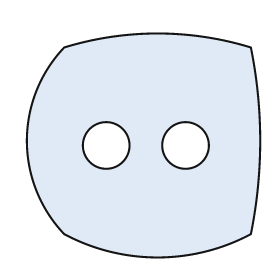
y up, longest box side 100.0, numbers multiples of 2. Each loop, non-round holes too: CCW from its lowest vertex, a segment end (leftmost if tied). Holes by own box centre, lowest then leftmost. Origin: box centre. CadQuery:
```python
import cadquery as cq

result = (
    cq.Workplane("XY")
    .moveTo(-34.0, -38.0)
    .threePointArc((6.0, -48.0), (46.0, -38.0))
    .threePointArc((50.0, 2.0), (46.0, 42.0))
    .threePointArc((6.0, 48.0), (-34.0, 42.0))
    .threePointArc((-50.0, 2.0), (-34.0, -38.0))
    .close()
    .moveTo(-16.0, 0.0)
    .circle(10.0)
    .moveTo(18.0, 0.0)
    .circle(10.0)
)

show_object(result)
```